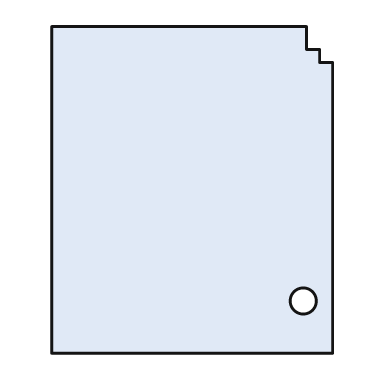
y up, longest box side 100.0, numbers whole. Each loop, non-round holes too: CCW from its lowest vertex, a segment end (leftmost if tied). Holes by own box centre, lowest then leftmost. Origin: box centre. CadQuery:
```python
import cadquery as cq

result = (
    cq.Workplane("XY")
    .moveTo(-43.0, -50.0)
    .lineTo(43.0, -50.0)
    .lineTo(43.0, 39.0)
    .lineTo(39.0, 39.0)
    .lineTo(39.0, 43.0)
    .lineTo(35.0, 43.0)
    .lineTo(35.0, 50.0)
    .lineTo(-43.0, 50.0)
    .close()
    .moveTo(34.0, -34.0)
    .circle(4.0)
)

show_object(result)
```